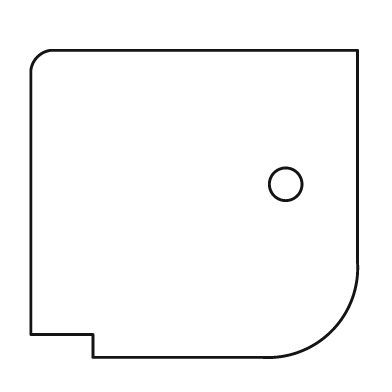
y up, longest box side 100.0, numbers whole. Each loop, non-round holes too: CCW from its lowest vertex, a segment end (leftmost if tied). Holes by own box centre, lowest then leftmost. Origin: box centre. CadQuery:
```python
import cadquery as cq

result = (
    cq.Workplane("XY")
    .moveTo(-31.0, -47.0)
    .lineTo(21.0, -47.0)
    .threePointArc((42.0, -39.0), (50.0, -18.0))
    .lineTo(50.0, 47.0)
    .lineTo(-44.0, 47.0)
    .threePointArc((-48.0, 45.0), (-50.0, 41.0))
    .lineTo(-50.0, -40.0)
    .lineTo(-31.0, -40.0)
    .close()
    .moveTo(28.0, 6.0)
    .circle(5.0)
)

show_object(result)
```